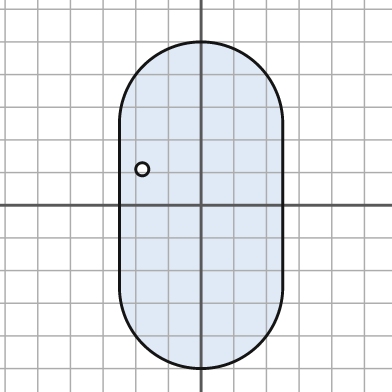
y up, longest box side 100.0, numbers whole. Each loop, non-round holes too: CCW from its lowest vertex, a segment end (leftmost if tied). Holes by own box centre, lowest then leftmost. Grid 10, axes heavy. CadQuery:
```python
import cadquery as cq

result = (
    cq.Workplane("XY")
    .moveTo(-25.0, -25.0)
    .threePointArc((0.0, -50.0), (25.0, -25.0))
    .lineTo(25.0, 25.0)
    .threePointArc((0.0, 50.0), (-25.0, 25.0))
    .close()
    .moveTo(-18.0, 11.0)
    .circle(2.0)
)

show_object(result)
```